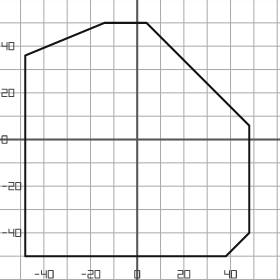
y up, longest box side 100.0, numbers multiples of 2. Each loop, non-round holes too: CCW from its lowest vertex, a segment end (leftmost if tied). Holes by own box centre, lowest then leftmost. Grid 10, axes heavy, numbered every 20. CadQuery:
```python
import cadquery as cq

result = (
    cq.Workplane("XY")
    .moveTo(-48.0, -50.0)
    .lineTo(38.0, -50.0)
    .lineTo(48.0, -40.0)
    .lineTo(48.0, 6.0)
    .lineTo(4.0, 50.0)
    .lineTo(-14.0, 50.0)
    .lineTo(-48.0, 36.0)
    .close()
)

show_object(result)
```